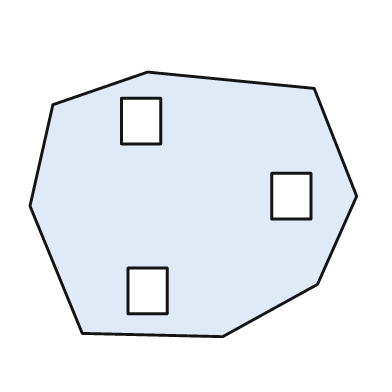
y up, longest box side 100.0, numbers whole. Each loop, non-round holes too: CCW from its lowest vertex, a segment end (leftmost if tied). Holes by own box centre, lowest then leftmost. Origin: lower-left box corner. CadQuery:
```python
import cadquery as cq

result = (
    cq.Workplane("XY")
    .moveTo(59.0, 0.0)
    .lineTo(88.0, 16.0)
    .lineTo(100.0, 43.0)
    .lineTo(87.0, 76.0)
    .lineTo(36.0, 81.0)
    .lineTo(7.0, 71.0)
    .lineTo(0.0, 40.0)
    .lineTo(16.0, 1.0)
    .close()
    .moveTo(30.0, 7.0)
    .lineTo(42.0, 7.0)
    .lineTo(42.0, 21.0)
    .lineTo(30.0, 21.0)
    .close()
    .moveTo(74.0, 36.0)
    .lineTo(86.0, 36.0)
    .lineTo(86.0, 50.0)
    .lineTo(74.0, 50.0)
    .close()
    .moveTo(28.0, 59.0)
    .lineTo(40.0, 59.0)
    .lineTo(40.0, 73.0)
    .lineTo(28.0, 73.0)
    .close()
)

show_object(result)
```